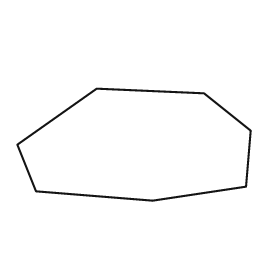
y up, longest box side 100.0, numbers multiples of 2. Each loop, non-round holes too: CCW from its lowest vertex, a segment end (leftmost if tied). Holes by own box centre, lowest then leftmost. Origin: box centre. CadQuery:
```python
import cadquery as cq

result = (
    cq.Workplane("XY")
    .moveTo(8.0, -24.0)
    .lineTo(48.0, -18.0)
    .lineTo(50.0, 6.0)
    .lineTo(30.0, 22.0)
    .lineTo(-16.0, 24.0)
    .lineTo(-50.0, 0.0)
    .lineTo(-42.0, -20.0)
    .close()
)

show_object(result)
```